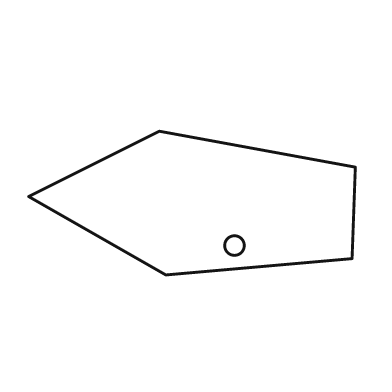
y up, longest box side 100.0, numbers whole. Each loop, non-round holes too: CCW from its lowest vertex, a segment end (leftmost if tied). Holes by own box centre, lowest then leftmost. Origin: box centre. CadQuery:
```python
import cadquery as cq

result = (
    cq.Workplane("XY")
    .moveTo(-8.0, -22.0)
    .lineTo(49.0, -17.0)
    .lineTo(50.0, 11.0)
    .lineTo(-10.0, 22.0)
    .lineTo(-50.0, 2.0)
    .close()
    .moveTo(13.0, -13.0)
    .circle(3.0)
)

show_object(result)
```